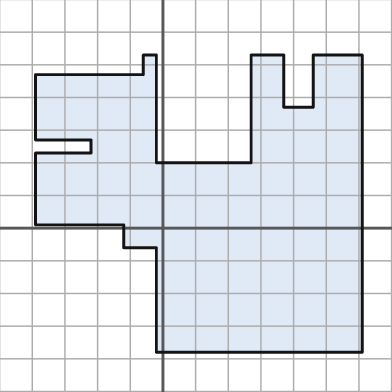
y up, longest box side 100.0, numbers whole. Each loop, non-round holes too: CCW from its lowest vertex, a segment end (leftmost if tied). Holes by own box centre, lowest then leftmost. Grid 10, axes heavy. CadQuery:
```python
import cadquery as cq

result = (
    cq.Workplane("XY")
    .moveTo(-2.0, -38.0)
    .lineTo(61.0, -38.0)
    .lineTo(61.0, 53.0)
    .lineTo(46.0, 53.0)
    .lineTo(46.0, 37.0)
    .lineTo(37.0, 37.0)
    .lineTo(37.0, 53.0)
    .lineTo(27.0, 53.0)
    .lineTo(27.0, 20.0)
    .lineTo(-2.0, 20.0)
    .lineTo(-2.0, 53.0)
    .lineTo(-6.0, 53.0)
    .lineTo(-6.0, 47.0)
    .lineTo(-39.0, 47.0)
    .lineTo(-39.0, 27.0)
    .lineTo(-22.0, 27.0)
    .lineTo(-22.0, 23.0)
    .lineTo(-39.0, 23.0)
    .lineTo(-39.0, 1.0)
    .lineTo(-12.0, 1.0)
    .lineTo(-12.0, -6.0)
    .lineTo(-2.0, -6.0)
    .close()
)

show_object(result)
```